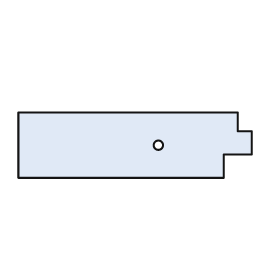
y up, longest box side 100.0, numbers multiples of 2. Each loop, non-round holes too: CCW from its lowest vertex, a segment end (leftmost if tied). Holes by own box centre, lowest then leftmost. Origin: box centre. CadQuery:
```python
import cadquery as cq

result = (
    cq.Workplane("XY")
    .moveTo(-50.0, -14.0)
    .lineTo(38.0, -14.0)
    .lineTo(38.0, -4.0)
    .lineTo(50.0, -4.0)
    .lineTo(50.0, 6.0)
    .lineTo(44.0, 6.0)
    .lineTo(44.0, 14.0)
    .lineTo(-50.0, 14.0)
    .close()
    .moveTo(10.0, 0.0)
    .circle(2.0)
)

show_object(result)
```